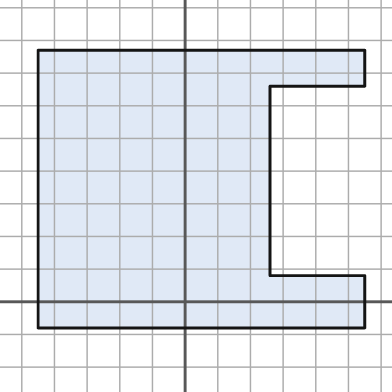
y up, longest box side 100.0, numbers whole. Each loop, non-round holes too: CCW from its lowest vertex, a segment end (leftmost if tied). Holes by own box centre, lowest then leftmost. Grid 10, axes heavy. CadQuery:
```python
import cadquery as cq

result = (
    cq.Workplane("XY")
    .moveTo(-45.0, -8.0)
    .lineTo(55.0, -8.0)
    .lineTo(55.0, 8.0)
    .lineTo(26.0, 8.0)
    .lineTo(26.0, 66.0)
    .lineTo(55.0, 66.0)
    .lineTo(55.0, 77.0)
    .lineTo(-45.0, 77.0)
    .close()
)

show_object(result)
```